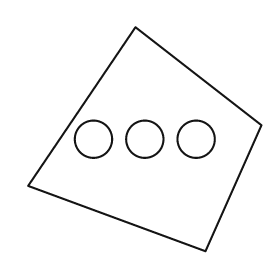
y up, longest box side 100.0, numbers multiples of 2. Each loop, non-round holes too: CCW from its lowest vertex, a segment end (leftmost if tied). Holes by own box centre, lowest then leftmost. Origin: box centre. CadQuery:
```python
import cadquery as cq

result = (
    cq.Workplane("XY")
    .moveTo(26.0, -48.0)
    .lineTo(50.0, 6.0)
    .lineTo(-4.0, 48.0)
    .lineTo(-50.0, -20.0)
    .close()
    .moveTo(-22.0, 0.0)
    .circle(8.0)
    .moveTo(0.0, 0.0)
    .circle(8.0)
    .moveTo(22.0, 0.0)
    .circle(8.0)
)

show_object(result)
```